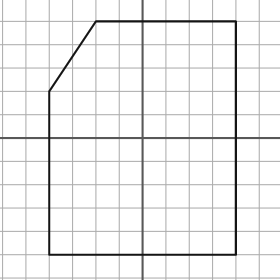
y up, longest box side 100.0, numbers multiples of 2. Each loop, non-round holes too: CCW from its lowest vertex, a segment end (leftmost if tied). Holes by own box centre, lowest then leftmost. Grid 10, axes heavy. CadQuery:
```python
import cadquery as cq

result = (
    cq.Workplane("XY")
    .moveTo(-40.0, -50.0)
    .lineTo(40.0, -50.0)
    .lineTo(40.0, 50.0)
    .lineTo(-20.0, 50.0)
    .lineTo(-40.0, 20.0)
    .close()
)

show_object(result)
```